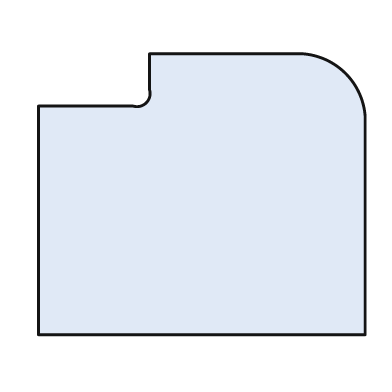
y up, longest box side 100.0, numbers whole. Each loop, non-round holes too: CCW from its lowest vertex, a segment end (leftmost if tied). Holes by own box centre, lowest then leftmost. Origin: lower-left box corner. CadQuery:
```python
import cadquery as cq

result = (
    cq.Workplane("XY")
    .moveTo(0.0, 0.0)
    .lineTo(100.0, 0.0)
    .lineTo(100.0, 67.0)
    .threePointArc((94.0, 80.0), (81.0, 86.0))
    .lineTo(34.0, 86.0)
    .lineTo(34.0, 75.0)
    .threePointArc((33.0, 71.0), (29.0, 70.0))
    .lineTo(0.0, 70.0)
    .close()
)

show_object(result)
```